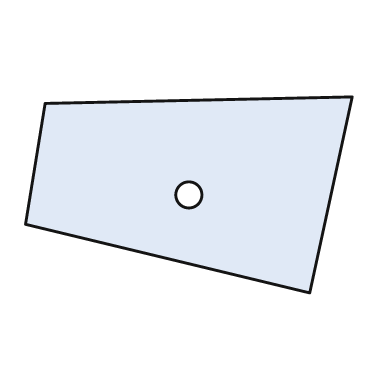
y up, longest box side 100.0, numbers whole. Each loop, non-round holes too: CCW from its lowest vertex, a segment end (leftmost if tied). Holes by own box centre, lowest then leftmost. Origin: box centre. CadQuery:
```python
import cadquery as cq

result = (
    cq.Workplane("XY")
    .moveTo(37.0, -30.0)
    .lineTo(50.0, 30.0)
    .lineTo(-44.0, 28.0)
    .lineTo(-50.0, -9.0)
    .close()
    .moveTo(0.0, 0.0)
    .circle(4.0)
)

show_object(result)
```